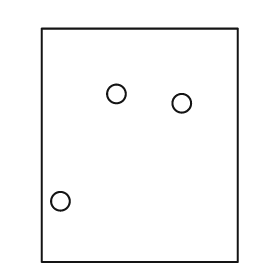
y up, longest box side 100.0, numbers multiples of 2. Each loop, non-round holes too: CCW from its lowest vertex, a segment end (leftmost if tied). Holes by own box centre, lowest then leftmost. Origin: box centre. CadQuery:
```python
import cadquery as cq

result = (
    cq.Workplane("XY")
    .moveTo(-42.0, -50.0)
    .lineTo(42.0, -50.0)
    .lineTo(42.0, 50.0)
    .lineTo(-42.0, 50.0)
    .close()
    .moveTo(-34.0, -24.0)
    .circle(4.0)
    .moveTo(18.0, 18.0)
    .circle(4.0)
    .moveTo(-10.0, 22.0)
    .circle(4.0)
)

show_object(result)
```